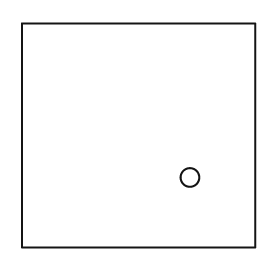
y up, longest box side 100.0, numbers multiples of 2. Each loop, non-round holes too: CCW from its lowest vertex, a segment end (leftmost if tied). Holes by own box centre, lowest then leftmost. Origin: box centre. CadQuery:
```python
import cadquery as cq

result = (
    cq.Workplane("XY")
    .moveTo(-50.0, -48.0)
    .lineTo(50.0, -48.0)
    .lineTo(50.0, 48.0)
    .lineTo(-50.0, 48.0)
    .close()
    .moveTo(22.0, -18.0)
    .circle(4.0)
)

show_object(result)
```